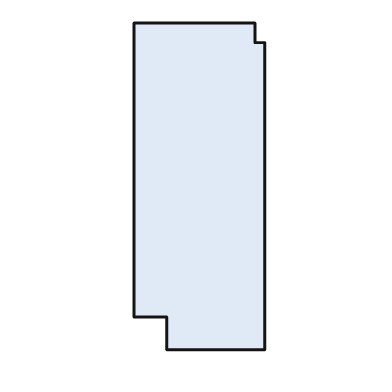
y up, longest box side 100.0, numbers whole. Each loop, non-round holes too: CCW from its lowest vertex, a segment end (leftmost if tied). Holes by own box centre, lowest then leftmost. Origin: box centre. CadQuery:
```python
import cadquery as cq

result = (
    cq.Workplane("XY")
    .moveTo(-10.0, -50.0)
    .lineTo(20.0, -50.0)
    .lineTo(20.0, 44.0)
    .lineTo(17.0, 44.0)
    .lineTo(17.0, 50.0)
    .lineTo(-20.0, 50.0)
    .lineTo(-20.0, -40.0)
    .lineTo(-10.0, -40.0)
    .close()
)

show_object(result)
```